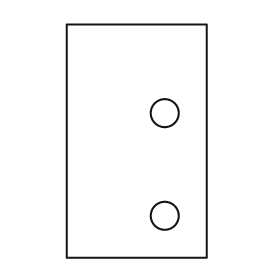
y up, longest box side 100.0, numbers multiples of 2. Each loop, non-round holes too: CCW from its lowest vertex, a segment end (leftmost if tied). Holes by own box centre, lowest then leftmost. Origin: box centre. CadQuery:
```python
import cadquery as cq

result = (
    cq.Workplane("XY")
    .moveTo(-30.0, -50.0)
    .lineTo(30.0, -50.0)
    .lineTo(30.0, 50.0)
    .lineTo(-30.0, 50.0)
    .close()
    .moveTo(12.0, -32.0)
    .circle(6.0)
    .moveTo(12.0, 12.0)
    .circle(6.0)
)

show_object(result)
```